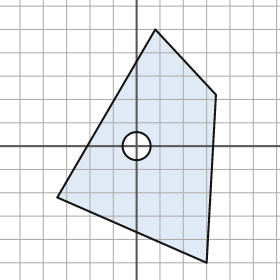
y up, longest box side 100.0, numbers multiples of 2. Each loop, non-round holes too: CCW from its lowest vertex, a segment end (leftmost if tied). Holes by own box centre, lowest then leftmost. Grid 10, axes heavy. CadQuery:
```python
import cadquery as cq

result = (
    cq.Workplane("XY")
    .moveTo(30.0, -50.0)
    .lineTo(34.0, 22.0)
    .lineTo(8.0, 50.0)
    .lineTo(-34.0, -22.0)
    .close()
    .moveTo(0.0, 0.0)
    .circle(6.0)
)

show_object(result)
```